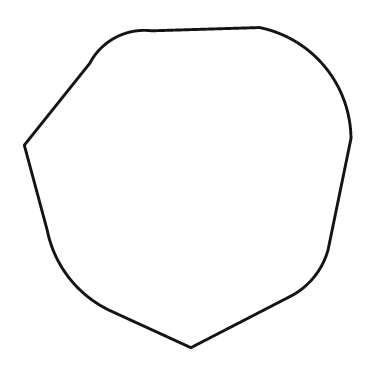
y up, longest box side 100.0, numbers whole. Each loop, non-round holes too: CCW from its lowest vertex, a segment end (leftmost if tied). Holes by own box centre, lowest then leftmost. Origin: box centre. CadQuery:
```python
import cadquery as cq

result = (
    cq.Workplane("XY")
    .moveTo(1.0, -49.0)
    .lineTo(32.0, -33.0)
    .threePointArc((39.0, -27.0), (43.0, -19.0))
    .lineTo(50.0, 15.0)
    .threePointArc((42.0, 37.0), (22.0, 49.0))
    .lineTo(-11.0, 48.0)
    .threePointArc((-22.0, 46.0), (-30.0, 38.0))
    .lineTo(-50.0, 13.0)
    .lineTo(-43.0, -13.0)
    .threePointArc((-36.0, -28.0), (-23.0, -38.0))
    .close()
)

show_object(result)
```